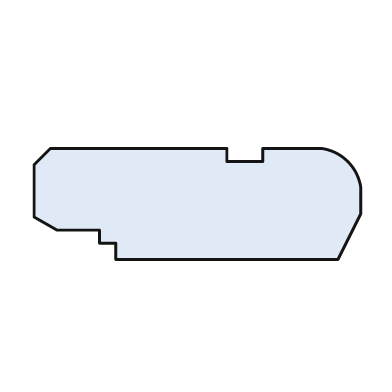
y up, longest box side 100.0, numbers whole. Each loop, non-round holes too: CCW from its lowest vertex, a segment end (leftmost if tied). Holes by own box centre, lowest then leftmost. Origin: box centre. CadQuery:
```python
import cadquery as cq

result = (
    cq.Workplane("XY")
    .moveTo(-25.0, -17.0)
    .lineTo(43.0, -17.0)
    .lineTo(50.0, -3.0)
    .lineTo(50.0, 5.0)
    .threePointArc((46.0, 13.0), (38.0, 17.0))
    .lineTo(20.0, 17.0)
    .lineTo(20.0, 13.0)
    .lineTo(9.0, 13.0)
    .lineTo(9.0, 17.0)
    .lineTo(-45.0, 17.0)
    .lineTo(-50.0, 12.0)
    .lineTo(-50.0, -4.0)
    .lineTo(-43.0, -8.0)
    .lineTo(-30.0, -8.0)
    .lineTo(-30.0, -12.0)
    .lineTo(-25.0, -12.0)
    .close()
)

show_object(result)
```